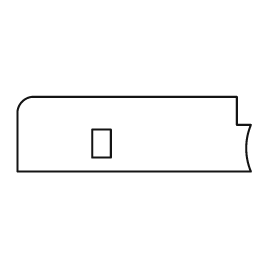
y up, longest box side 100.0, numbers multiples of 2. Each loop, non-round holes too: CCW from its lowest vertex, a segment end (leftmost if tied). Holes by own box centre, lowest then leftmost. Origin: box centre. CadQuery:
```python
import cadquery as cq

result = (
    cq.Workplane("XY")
    .moveTo(-50.0, -16.0)
    .lineTo(50.0, -16.0)
    .threePointArc((48.0, -6.0), (50.0, 4.0))
    .lineTo(44.0, 4.0)
    .lineTo(44.0, 16.0)
    .lineTo(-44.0, 16.0)
    .threePointArc((-48.0, 14.0), (-50.0, 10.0))
    .close()
    .moveTo(-18.0, -10.0)
    .lineTo(-10.0, -10.0)
    .lineTo(-10.0, 2.0)
    .lineTo(-18.0, 2.0)
    .close()
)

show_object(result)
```